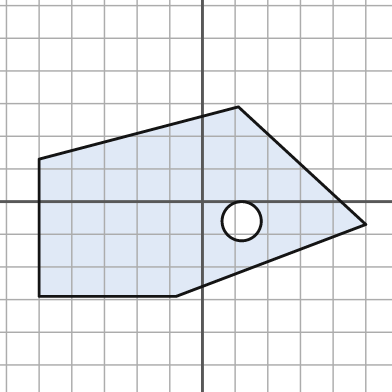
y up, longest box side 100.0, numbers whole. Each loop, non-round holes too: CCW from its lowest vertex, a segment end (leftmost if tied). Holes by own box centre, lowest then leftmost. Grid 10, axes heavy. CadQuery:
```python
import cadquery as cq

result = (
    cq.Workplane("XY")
    .moveTo(-50.0, -29.0)
    .lineTo(-8.0, -29.0)
    .lineTo(50.0, -7.0)
    .lineTo(11.0, 29.0)
    .lineTo(-50.0, 13.0)
    .close()
    .moveTo(12.0, -6.0)
    .circle(6.0)
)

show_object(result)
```